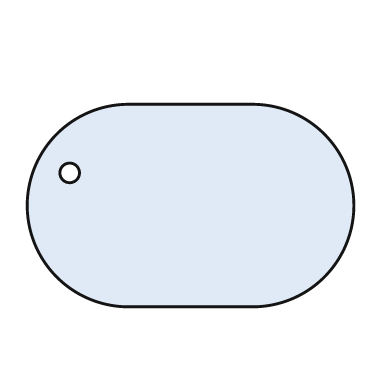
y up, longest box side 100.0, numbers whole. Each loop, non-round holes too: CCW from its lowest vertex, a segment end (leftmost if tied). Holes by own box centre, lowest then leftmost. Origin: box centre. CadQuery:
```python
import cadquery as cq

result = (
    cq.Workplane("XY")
    .moveTo(-19.0, -31.0)
    .lineTo(19.0, -31.0)
    .threePointArc((50.0, 0.0), (19.0, 31.0))
    .lineTo(-19.0, 31.0)
    .threePointArc((-50.0, 0.0), (-19.0, -31.0))
    .close()
    .moveTo(-37.0, 10.0)
    .circle(3.0)
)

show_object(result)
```